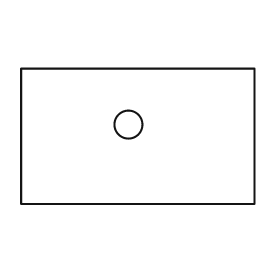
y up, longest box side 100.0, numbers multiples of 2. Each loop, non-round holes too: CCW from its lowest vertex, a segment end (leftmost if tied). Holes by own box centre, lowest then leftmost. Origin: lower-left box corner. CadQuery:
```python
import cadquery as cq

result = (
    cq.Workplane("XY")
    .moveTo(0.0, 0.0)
    .lineTo(100.0, 0.0)
    .lineTo(100.0, 58.0)
    .lineTo(0.0, 58.0)
    .close()
    .moveTo(46.0, 34.0)
    .circle(6.0)
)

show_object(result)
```